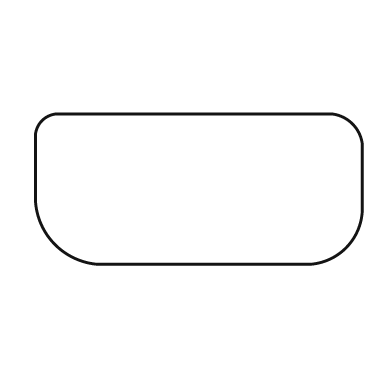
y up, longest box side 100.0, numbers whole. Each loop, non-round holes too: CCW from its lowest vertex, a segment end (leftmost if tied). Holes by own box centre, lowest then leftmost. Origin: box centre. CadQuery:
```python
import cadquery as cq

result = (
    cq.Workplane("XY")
    .moveTo(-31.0, -23.0)
    .lineTo(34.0, -23.0)
    .threePointArc((45.0, -18.0), (50.0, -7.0))
    .lineTo(50.0, 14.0)
    .threePointArc((47.0, 20.0), (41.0, 23.0))
    .lineTo(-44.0, 23.0)
    .threePointArc((-48.0, 21.0), (-50.0, 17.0))
    .lineTo(-50.0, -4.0)
    .threePointArc((-44.0, -17.0), (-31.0, -23.0))
    .close()
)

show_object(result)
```